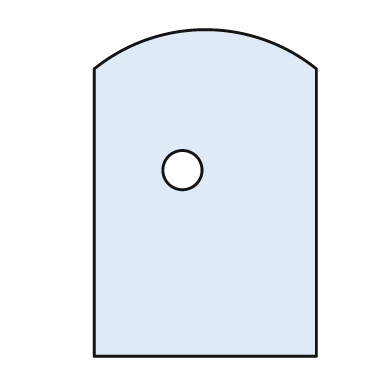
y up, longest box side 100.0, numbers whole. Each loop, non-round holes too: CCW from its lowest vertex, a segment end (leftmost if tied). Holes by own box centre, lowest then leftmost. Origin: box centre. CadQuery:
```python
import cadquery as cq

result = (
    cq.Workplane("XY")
    .moveTo(-34.0, -50.0)
    .lineTo(34.0, -50.0)
    .lineTo(34.0, 38.0)
    .threePointArc((0.0, 50.0), (-34.0, 38.0))
    .close()
    .moveTo(-7.0, 7.0)
    .circle(6.0)
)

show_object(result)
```